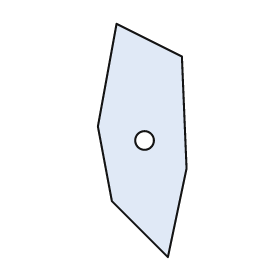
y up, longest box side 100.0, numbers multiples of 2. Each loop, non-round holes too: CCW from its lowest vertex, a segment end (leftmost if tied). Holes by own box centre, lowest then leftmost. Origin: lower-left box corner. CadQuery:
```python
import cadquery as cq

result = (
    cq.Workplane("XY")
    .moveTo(30.0, 0.0)
    .lineTo(38.0, 38.0)
    .lineTo(36.0, 86.0)
    .lineTo(8.0, 100.0)
    .lineTo(0.0, 56.0)
    .lineTo(6.0, 24.0)
    .close()
    .moveTo(20.0, 50.0)
    .circle(4.0)
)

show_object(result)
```